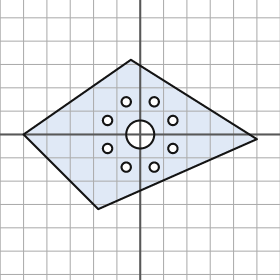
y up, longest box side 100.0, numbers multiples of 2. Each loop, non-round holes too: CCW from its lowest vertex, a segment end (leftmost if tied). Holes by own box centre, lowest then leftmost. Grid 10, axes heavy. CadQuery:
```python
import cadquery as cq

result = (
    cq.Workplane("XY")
    .moveTo(-18.0, -32.0)
    .lineTo(50.0, -2.0)
    .lineTo(-4.0, 32.0)
    .lineTo(-50.0, 0.0)
    .close()
    .moveTo(-6.0, -14.0)
    .circle(2.0)
    .moveTo(6.0, -14.0)
    .circle(2.0)
    .moveTo(-14.0, -6.0)
    .circle(2.0)
    .moveTo(14.0, -6.0)
    .circle(2.0)
    .moveTo(0.0, 0.0)
    .circle(6.0)
    .moveTo(-14.0, 6.0)
    .circle(2.0)
    .moveTo(14.0, 6.0)
    .circle(2.0)
    .moveTo(-6.0, 14.0)
    .circle(2.0)
    .moveTo(6.0, 14.0)
    .circle(2.0)
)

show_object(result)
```